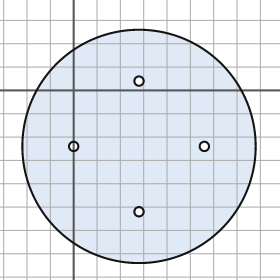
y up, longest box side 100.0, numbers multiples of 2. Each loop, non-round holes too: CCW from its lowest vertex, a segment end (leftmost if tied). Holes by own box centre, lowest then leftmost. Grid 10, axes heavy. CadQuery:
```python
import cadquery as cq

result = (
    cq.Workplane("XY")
    .moveTo(28.0, -24.0)
    .circle(50.0)
    .moveTo(28.0, -52.0)
    .circle(2.0)
    .moveTo(0.0, -24.0)
    .circle(2.0)
    .moveTo(56.0, -24.0)
    .circle(2.0)
    .moveTo(28.0, 4.0)
    .circle(2.0)
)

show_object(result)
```